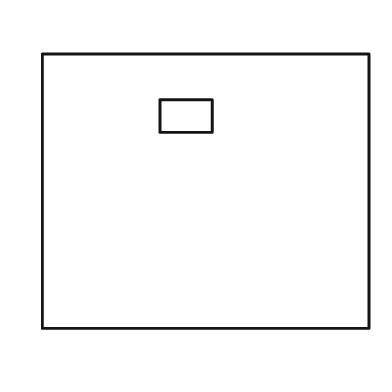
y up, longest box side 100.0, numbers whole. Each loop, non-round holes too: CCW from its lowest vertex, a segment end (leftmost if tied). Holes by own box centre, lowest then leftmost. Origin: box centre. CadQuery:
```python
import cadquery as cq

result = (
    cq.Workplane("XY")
    .moveTo(-50.0, -42.0)
    .lineTo(50.0, -42.0)
    .lineTo(50.0, 42.0)
    .lineTo(-50.0, 42.0)
    .close()
    .moveTo(-14.0, 18.0)
    .lineTo(2.0, 18.0)
    .lineTo(2.0, 28.0)
    .lineTo(-14.0, 28.0)
    .close()
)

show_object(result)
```